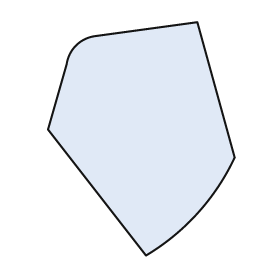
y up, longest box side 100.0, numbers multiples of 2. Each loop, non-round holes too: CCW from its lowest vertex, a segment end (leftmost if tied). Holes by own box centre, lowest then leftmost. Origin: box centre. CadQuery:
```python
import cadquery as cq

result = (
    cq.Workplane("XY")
    .moveTo(2.0, -50.0)
    .threePointArc((24.0, -32.0), (40.0, -8.0))
    .lineTo(24.0, 50.0)
    .lineTo(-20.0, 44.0)
    .threePointArc((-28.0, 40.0), (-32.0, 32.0))
    .lineTo(-40.0, 4.0)
    .close()
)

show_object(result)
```